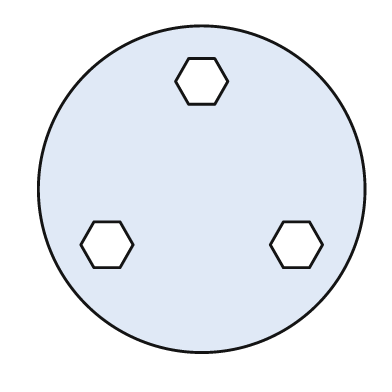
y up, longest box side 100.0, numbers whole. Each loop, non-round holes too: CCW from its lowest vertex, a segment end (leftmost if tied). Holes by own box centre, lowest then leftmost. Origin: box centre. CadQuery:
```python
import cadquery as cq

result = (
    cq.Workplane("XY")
    .moveTo(0.0, 0.0)
    .circle(50.0)
    .moveTo(-33.0, -24.0)
    .lineTo(-25.0, -24.0)
    .lineTo(-21.0, -17.0)
    .lineTo(-25.0, -10.0)
    .lineTo(-33.0, -10.0)
    .lineTo(-37.0, -17.0)
    .close()
    .moveTo(25.0, -24.0)
    .lineTo(33.0, -24.0)
    .lineTo(37.0, -17.0)
    .lineTo(33.0, -10.0)
    .lineTo(25.0, -10.0)
    .lineTo(21.0, -17.0)
    .close()
    .moveTo(-4.0, 26.0)
    .lineTo(4.0, 26.0)
    .lineTo(8.0, 33.0)
    .lineTo(4.0, 40.0)
    .lineTo(-4.0, 40.0)
    .lineTo(-8.0, 33.0)
    .close()
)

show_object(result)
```